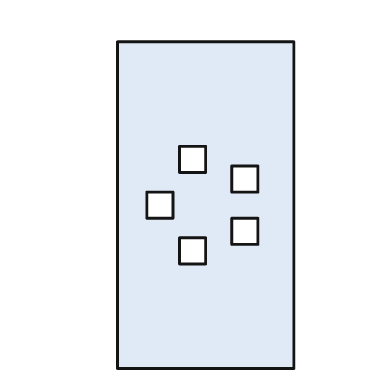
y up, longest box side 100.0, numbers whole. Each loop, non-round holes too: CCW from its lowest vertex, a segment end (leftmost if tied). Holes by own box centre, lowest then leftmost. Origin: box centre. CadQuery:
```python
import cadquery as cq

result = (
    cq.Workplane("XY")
    .moveTo(-27.0, -50.0)
    .lineTo(27.0, -50.0)
    .lineTo(27.0, 50.0)
    .lineTo(-27.0, 50.0)
    .close()
    .moveTo(-8.0, -18.0)
    .lineTo(0.0, -18.0)
    .lineTo(0.0, -10.0)
    .lineTo(-8.0, -10.0)
    .close()
    .moveTo(8.0, -12.0)
    .lineTo(16.0, -12.0)
    .lineTo(16.0, -4.0)
    .lineTo(8.0, -4.0)
    .close()
    .moveTo(-18.0, -4.0)
    .lineTo(-10.0, -4.0)
    .lineTo(-10.0, 4.0)
    .lineTo(-18.0, 4.0)
    .close()
    .moveTo(8.0, 4.0)
    .lineTo(16.0, 4.0)
    .lineTo(16.0, 12.0)
    .lineTo(8.0, 12.0)
    .close()
    .moveTo(-8.0, 10.0)
    .lineTo(0.0, 10.0)
    .lineTo(0.0, 18.0)
    .lineTo(-8.0, 18.0)
    .close()
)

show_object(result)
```